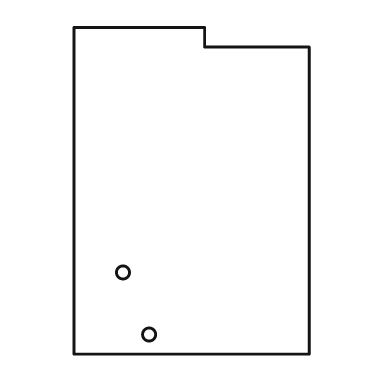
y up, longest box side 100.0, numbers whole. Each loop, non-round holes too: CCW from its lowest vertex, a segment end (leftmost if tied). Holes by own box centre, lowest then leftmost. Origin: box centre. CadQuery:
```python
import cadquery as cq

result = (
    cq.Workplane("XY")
    .moveTo(-36.0, -50.0)
    .lineTo(36.0, -50.0)
    .lineTo(36.0, 44.0)
    .lineTo(4.0, 44.0)
    .lineTo(4.0, 50.0)
    .lineTo(-36.0, 50.0)
    .close()
    .moveTo(-13.0, -44.0)
    .circle(2.0)
    .moveTo(-21.0, -25.0)
    .circle(2.0)
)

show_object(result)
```